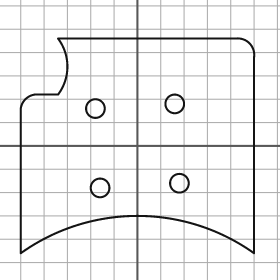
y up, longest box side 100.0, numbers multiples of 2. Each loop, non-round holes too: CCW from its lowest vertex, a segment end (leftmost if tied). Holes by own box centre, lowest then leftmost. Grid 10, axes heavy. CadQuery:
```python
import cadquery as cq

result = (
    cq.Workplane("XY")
    .moveTo(-50.0, -46.0)
    .threePointArc((0.0, -30.0), (50.0, -46.0))
    .lineTo(50.0, 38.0)
    .threePointArc((48.0, 44.0), (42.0, 46.0))
    .lineTo(-34.0, 46.0)
    .threePointArc((-30.0, 34.0), (-34.0, 22.0))
    .lineTo(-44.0, 22.0)
    .threePointArc((-48.0, 20.0), (-50.0, 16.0))
    .close()
    .moveTo(-16.0, -18.0)
    .circle(4.0)
    .moveTo(18.0, -16.0)
    .circle(4.0)
    .moveTo(-18.0, 16.0)
    .circle(4.0)
    .moveTo(16.0, 18.0)
    .circle(4.0)
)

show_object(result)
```